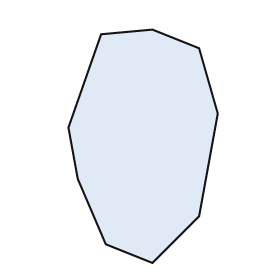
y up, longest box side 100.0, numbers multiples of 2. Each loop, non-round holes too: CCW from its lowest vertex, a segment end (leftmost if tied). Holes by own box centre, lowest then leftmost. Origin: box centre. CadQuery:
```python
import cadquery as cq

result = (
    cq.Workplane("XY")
    .moveTo(4.0, -50.0)
    .lineTo(24.0, -30.0)
    .lineTo(32.0, 14.0)
    .lineTo(24.0, 42.0)
    .lineTo(4.0, 50.0)
    .lineTo(-18.0, 48.0)
    .lineTo(-32.0, 8.0)
    .lineTo(-28.0, -14.0)
    .lineTo(-16.0, -42.0)
    .close()
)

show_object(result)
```